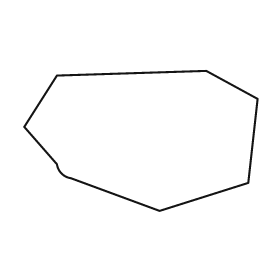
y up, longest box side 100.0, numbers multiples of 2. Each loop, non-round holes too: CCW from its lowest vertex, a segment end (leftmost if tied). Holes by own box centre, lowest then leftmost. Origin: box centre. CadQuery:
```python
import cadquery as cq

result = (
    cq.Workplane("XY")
    .moveTo(8.0, -30.0)
    .lineTo(46.0, -18.0)
    .lineTo(50.0, 18.0)
    .lineTo(28.0, 30.0)
    .lineTo(-36.0, 28.0)
    .lineTo(-50.0, 6.0)
    .lineTo(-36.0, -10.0)
    .threePointArc((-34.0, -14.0), (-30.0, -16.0))
    .close()
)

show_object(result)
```